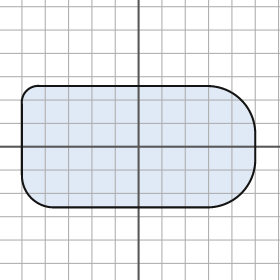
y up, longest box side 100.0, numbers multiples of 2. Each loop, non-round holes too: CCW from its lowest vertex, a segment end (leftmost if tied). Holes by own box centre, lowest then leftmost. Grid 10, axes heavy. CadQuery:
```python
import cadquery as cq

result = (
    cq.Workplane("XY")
    .moveTo(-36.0, -26.0)
    .lineTo(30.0, -26.0)
    .threePointArc((44.0, -20.0), (50.0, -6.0))
    .lineTo(50.0, 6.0)
    .threePointArc((44.0, 20.0), (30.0, 26.0))
    .lineTo(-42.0, 26.0)
    .threePointArc((-48.0, 24.0), (-50.0, 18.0))
    .lineTo(-50.0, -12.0)
    .threePointArc((-46.0, -22.0), (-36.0, -26.0))
    .close()
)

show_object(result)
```